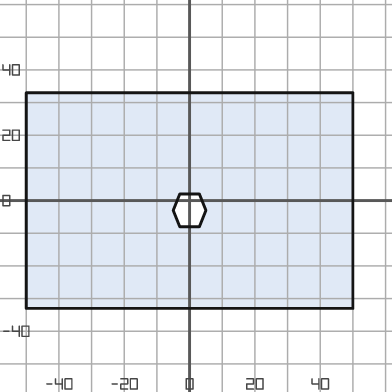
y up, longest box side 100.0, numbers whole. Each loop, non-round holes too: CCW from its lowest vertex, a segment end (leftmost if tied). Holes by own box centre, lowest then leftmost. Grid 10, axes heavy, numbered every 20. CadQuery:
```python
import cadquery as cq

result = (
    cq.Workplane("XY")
    .moveTo(-50.0, -33.0)
    .lineTo(50.0, -33.0)
    .lineTo(50.0, 33.0)
    .lineTo(-50.0, 33.0)
    .close()
    .moveTo(-3.0, -8.0)
    .lineTo(3.0, -8.0)
    .lineTo(5.0, -3.0)
    .lineTo(3.0, 2.0)
    .lineTo(-3.0, 2.0)
    .lineTo(-5.0, -3.0)
    .close()
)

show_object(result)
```